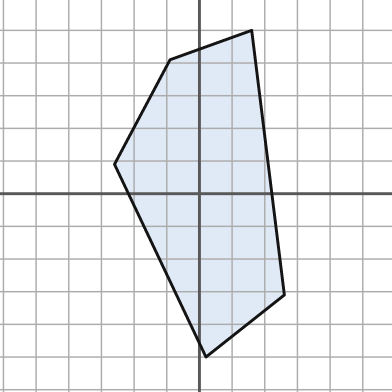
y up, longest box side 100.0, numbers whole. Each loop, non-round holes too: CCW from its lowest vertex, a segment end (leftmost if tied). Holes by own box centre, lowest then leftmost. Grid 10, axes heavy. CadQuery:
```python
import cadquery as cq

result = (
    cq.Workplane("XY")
    .moveTo(2.0, -50.0)
    .lineTo(26.0, -31.0)
    .lineTo(16.0, 50.0)
    .lineTo(-9.0, 41.0)
    .lineTo(-26.0, 9.0)
    .close()
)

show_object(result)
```